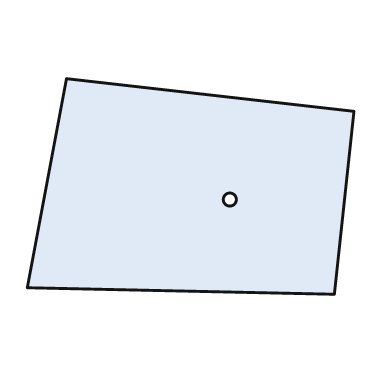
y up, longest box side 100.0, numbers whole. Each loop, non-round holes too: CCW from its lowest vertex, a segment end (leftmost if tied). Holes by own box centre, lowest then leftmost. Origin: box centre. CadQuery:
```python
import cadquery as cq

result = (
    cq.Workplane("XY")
    .moveTo(44.0, -33.0)
    .lineTo(50.0, 23.0)
    .lineTo(-38.0, 33.0)
    .lineTo(-50.0, -31.0)
    .close()
    .moveTo(12.0, -4.0)
    .circle(2.0)
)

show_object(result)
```